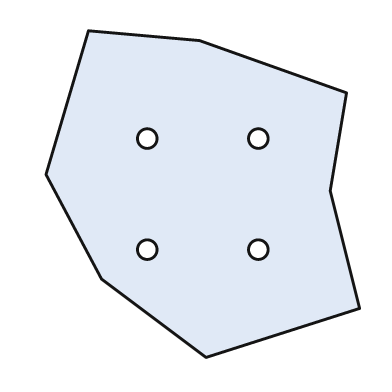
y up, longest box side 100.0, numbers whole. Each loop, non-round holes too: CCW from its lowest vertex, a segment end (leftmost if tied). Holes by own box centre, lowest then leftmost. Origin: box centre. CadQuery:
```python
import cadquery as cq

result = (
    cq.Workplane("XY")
    .moveTo(1.0, -50.0)
    .lineTo(48.0, -35.0)
    .lineTo(39.0, 1.0)
    .lineTo(44.0, 31.0)
    .lineTo(-1.0, 47.0)
    .lineTo(-35.0, 50.0)
    .lineTo(-48.0, 6.0)
    .lineTo(-31.0, -26.0)
    .close()
    .moveTo(-17.0, -17.0)
    .circle(3.0)
    .moveTo(17.0, -17.0)
    .circle(3.0)
    .moveTo(-17.0, 17.0)
    .circle(3.0)
    .moveTo(17.0, 17.0)
    .circle(3.0)
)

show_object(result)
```